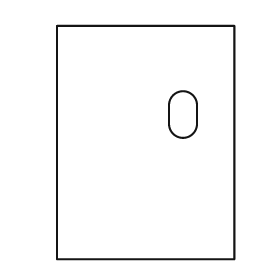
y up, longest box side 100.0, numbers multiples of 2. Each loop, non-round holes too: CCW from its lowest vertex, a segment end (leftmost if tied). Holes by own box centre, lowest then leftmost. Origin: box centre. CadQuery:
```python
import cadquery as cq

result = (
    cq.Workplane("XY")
    .moveTo(-38.0, -50.0)
    .lineTo(38.0, -50.0)
    .lineTo(38.0, 50.0)
    .lineTo(-38.0, 50.0)
    .close()
    .moveTo(10.0, 8.0)
    .threePointArc((16.0, 2.0), (22.0, 8.0))
    .lineTo(22.0, 16.0)
    .threePointArc((16.0, 22.0), (10.0, 16.0))
    .close()
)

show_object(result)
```